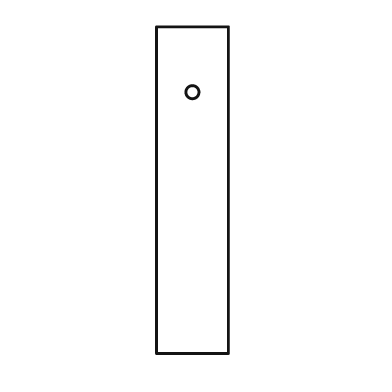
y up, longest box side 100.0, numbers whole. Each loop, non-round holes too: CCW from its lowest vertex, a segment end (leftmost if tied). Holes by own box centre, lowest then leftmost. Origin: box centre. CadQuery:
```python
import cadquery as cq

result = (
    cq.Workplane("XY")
    .moveTo(-11.0, -50.0)
    .lineTo(11.0, -50.0)
    .lineTo(11.0, 50.0)
    .lineTo(-11.0, 50.0)
    .close()
    .moveTo(0.0, 30.0)
    .circle(2.0)
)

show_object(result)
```